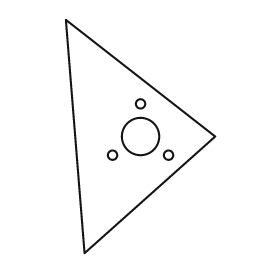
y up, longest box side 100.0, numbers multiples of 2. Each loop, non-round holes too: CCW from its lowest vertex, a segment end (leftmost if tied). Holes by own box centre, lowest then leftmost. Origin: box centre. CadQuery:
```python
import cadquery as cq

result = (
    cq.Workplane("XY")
    .moveTo(-24.0, -50.0)
    .lineTo(32.0, 0.0)
    .lineTo(-32.0, 50.0)
    .close()
    .moveTo(-12.0, -8.0)
    .circle(2.0)
    .moveTo(12.0, -8.0)
    .circle(2.0)
    .moveTo(0.0, 0.0)
    .circle(8.0)
    .moveTo(0.0, 14.0)
    .circle(2.0)
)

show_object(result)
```